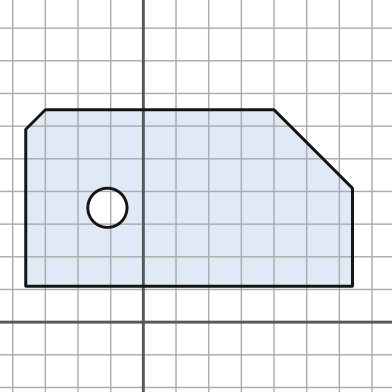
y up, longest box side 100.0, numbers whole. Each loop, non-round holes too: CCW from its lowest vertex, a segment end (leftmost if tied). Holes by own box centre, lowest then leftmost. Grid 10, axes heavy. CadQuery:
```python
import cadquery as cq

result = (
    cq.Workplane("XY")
    .moveTo(-36.0, 11.0)
    .lineTo(64.0, 11.0)
    .lineTo(64.0, 41.0)
    .lineTo(40.0, 65.0)
    .lineTo(-30.0, 65.0)
    .lineTo(-36.0, 59.0)
    .close()
    .moveTo(-11.0, 35.0)
    .circle(6.0)
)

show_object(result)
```